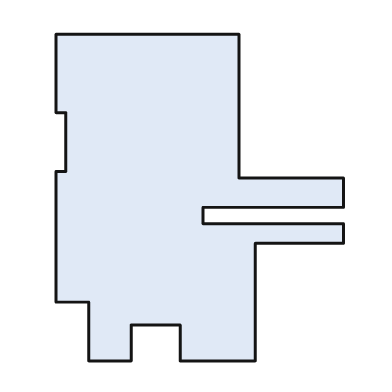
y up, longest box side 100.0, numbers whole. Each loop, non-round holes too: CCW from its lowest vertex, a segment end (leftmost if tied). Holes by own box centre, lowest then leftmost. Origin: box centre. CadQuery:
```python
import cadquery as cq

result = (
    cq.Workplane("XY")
    .moveTo(-34.0, -50.0)
    .lineTo(-21.0, -50.0)
    .lineTo(-21.0, -39.0)
    .lineTo(-6.0, -39.0)
    .lineTo(-6.0, -50.0)
    .lineTo(17.0, -50.0)
    .lineTo(17.0, -14.0)
    .lineTo(44.0, -14.0)
    .lineTo(44.0, -8.0)
    .lineTo(1.0, -8.0)
    .lineTo(1.0, -3.0)
    .lineTo(44.0, -3.0)
    .lineTo(44.0, 6.0)
    .lineTo(12.0, 6.0)
    .lineTo(12.0, 50.0)
    .lineTo(-44.0, 50.0)
    .lineTo(-44.0, 26.0)
    .lineTo(-41.0, 26.0)
    .lineTo(-41.0, 8.0)
    .lineTo(-44.0, 8.0)
    .lineTo(-44.0, -32.0)
    .lineTo(-34.0, -32.0)
    .close()
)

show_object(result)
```